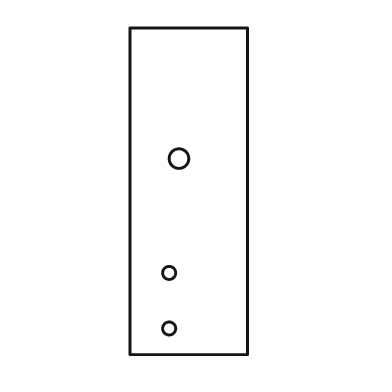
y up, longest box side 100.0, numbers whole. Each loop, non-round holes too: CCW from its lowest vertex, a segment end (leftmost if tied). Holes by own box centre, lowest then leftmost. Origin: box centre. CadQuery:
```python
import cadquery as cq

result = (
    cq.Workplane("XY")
    .moveTo(-18.0, -50.0)
    .lineTo(18.0, -50.0)
    .lineTo(18.0, 50.0)
    .lineTo(-18.0, 50.0)
    .close()
    .moveTo(-6.0, -42.0)
    .circle(2.0)
    .moveTo(-6.0, -25.0)
    .circle(2.0)
    .moveTo(-3.0, 10.0)
    .circle(3.0)
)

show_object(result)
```